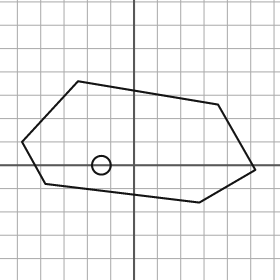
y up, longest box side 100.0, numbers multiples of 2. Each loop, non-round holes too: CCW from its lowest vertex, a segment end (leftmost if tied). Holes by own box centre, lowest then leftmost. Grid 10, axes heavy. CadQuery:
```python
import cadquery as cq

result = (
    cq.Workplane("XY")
    .moveTo(28.0, -16.0)
    .lineTo(52.0, -2.0)
    .lineTo(36.0, 26.0)
    .lineTo(-24.0, 36.0)
    .lineTo(-48.0, 10.0)
    .lineTo(-38.0, -8.0)
    .close()
    .moveTo(-14.0, 0.0)
    .circle(4.0)
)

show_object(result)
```